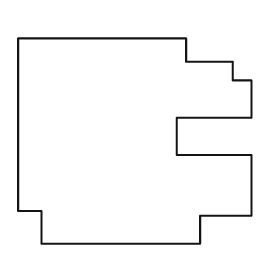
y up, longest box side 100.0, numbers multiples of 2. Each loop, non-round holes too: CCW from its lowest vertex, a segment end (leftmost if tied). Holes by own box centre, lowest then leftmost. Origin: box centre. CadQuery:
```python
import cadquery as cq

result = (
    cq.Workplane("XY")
    .moveTo(-40.0, -44.0)
    .lineTo(28.0, -44.0)
    .lineTo(28.0, -32.0)
    .lineTo(50.0, -32.0)
    .lineTo(50.0, -6.0)
    .lineTo(18.0, -6.0)
    .lineTo(18.0, 10.0)
    .lineTo(50.0, 10.0)
    .lineTo(50.0, 26.0)
    .lineTo(42.0, 26.0)
    .lineTo(42.0, 34.0)
    .lineTo(22.0, 34.0)
    .lineTo(22.0, 44.0)
    .lineTo(-50.0, 44.0)
    .lineTo(-50.0, -30.0)
    .lineTo(-40.0, -30.0)
    .close()
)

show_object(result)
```